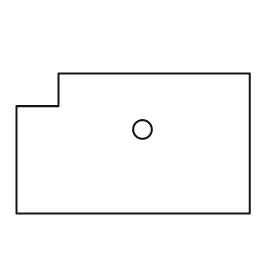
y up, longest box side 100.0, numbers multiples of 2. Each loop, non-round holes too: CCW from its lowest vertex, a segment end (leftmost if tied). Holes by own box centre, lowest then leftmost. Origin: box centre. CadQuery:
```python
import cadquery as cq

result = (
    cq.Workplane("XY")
    .moveTo(-50.0, -30.0)
    .lineTo(50.0, -30.0)
    .lineTo(50.0, 30.0)
    .lineTo(-32.0, 30.0)
    .lineTo(-32.0, 16.0)
    .lineTo(-50.0, 16.0)
    .close()
    .moveTo(4.0, 6.0)
    .circle(4.0)
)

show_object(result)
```